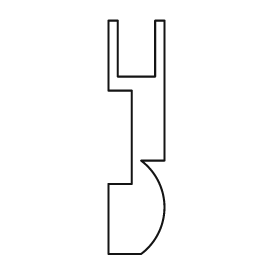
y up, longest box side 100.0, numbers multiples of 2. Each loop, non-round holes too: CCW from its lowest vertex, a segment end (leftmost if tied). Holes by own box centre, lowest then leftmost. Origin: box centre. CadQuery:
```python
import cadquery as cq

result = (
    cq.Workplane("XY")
    .moveTo(-12.0, -50.0)
    .lineTo(2.0, -50.0)
    .threePointArc((12.0, -30.0), (2.0, -10.0))
    .lineTo(12.0, -10.0)
    .lineTo(12.0, 50.0)
    .lineTo(8.0, 50.0)
    .lineTo(8.0, 26.0)
    .lineTo(-8.0, 26.0)
    .lineTo(-8.0, 50.0)
    .lineTo(-12.0, 50.0)
    .lineTo(-12.0, 20.0)
    .lineTo(-2.0, 20.0)
    .lineTo(-2.0, -20.0)
    .lineTo(-12.0, -20.0)
    .close()
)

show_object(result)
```